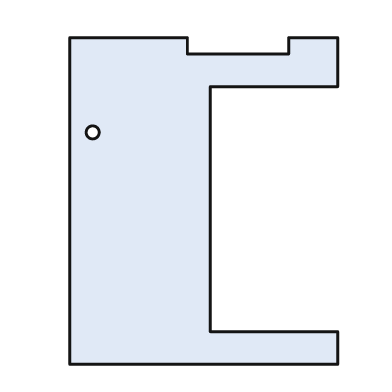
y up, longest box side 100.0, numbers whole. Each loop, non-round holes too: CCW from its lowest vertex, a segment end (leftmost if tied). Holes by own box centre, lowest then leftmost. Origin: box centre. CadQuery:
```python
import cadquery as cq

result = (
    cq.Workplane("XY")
    .moveTo(-41.0, -50.0)
    .lineTo(41.0, -50.0)
    .lineTo(41.0, -40.0)
    .lineTo(2.0, -40.0)
    .lineTo(2.0, 35.0)
    .lineTo(41.0, 35.0)
    .lineTo(41.0, 50.0)
    .lineTo(26.0, 50.0)
    .lineTo(26.0, 45.0)
    .lineTo(-5.0, 45.0)
    .lineTo(-5.0, 50.0)
    .lineTo(-41.0, 50.0)
    .close()
    .moveTo(-34.0, 21.0)
    .circle(2.0)
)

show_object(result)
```